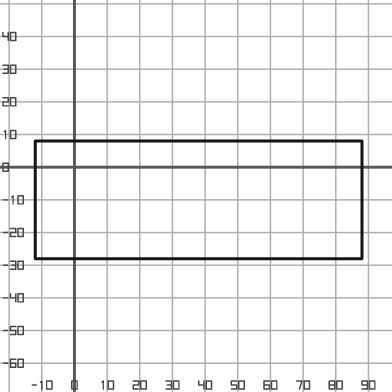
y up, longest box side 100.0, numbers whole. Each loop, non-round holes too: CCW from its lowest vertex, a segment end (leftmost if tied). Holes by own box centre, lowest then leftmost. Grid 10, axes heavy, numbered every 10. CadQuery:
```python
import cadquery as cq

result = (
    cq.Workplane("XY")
    .moveTo(-12.0, -28.0)
    .lineTo(88.0, -28.0)
    .lineTo(88.0, 8.0)
    .lineTo(-12.0, 8.0)
    .close()
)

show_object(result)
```